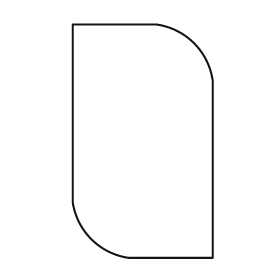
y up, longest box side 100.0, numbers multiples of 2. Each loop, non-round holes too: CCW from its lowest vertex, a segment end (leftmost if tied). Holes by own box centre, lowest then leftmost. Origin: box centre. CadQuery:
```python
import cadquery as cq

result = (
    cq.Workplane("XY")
    .moveTo(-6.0, -50.0)
    .lineTo(30.0, -50.0)
    .lineTo(30.0, 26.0)
    .threePointArc((22.0, 42.0), (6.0, 50.0))
    .lineTo(-30.0, 50.0)
    .lineTo(-30.0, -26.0)
    .threePointArc((-22.0, -42.0), (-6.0, -50.0))
    .close()
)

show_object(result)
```